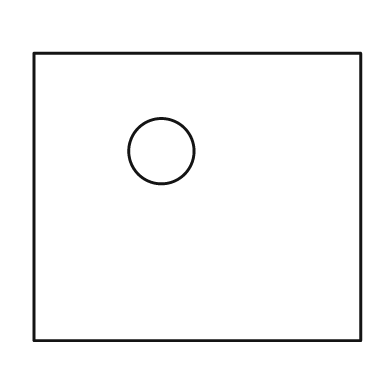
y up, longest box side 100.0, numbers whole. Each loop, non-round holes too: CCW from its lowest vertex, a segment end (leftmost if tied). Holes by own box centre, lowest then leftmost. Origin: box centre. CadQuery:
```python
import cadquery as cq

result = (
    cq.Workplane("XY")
    .moveTo(-50.0, -44.0)
    .lineTo(50.0, -44.0)
    .lineTo(50.0, 44.0)
    .lineTo(-50.0, 44.0)
    .close()
    .moveTo(-11.0, 14.0)
    .circle(10.0)
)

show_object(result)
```